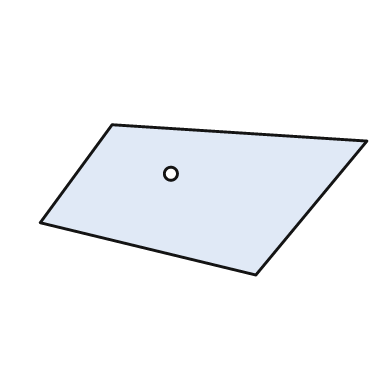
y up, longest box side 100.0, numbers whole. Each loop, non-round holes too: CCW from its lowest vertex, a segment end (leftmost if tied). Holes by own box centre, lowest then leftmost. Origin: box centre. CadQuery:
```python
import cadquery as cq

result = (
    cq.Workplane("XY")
    .moveTo(16.0, -23.0)
    .lineTo(50.0, 18.0)
    .lineTo(-28.0, 23.0)
    .lineTo(-50.0, -7.0)
    .close()
    .moveTo(-10.0, 8.0)
    .circle(2.0)
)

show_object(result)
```